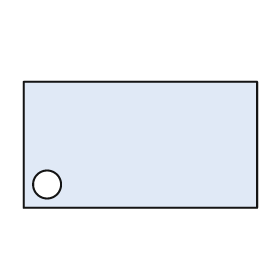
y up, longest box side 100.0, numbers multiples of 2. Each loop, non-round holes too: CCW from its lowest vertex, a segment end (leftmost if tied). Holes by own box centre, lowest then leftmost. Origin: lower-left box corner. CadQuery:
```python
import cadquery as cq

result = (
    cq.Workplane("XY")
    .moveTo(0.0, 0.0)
    .lineTo(100.0, 0.0)
    .lineTo(100.0, 54.0)
    .lineTo(0.0, 54.0)
    .close()
    .moveTo(10.0, 10.0)
    .circle(6.0)
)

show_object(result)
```